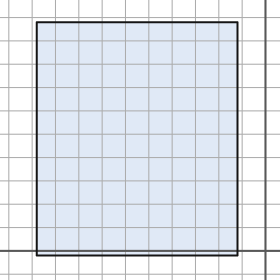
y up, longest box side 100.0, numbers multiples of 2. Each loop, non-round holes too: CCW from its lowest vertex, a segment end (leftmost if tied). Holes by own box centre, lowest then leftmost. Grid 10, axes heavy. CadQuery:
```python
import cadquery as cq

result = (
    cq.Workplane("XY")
    .moveTo(-98.0, -2.0)
    .lineTo(-12.0, -2.0)
    .lineTo(-12.0, 98.0)
    .lineTo(-98.0, 98.0)
    .close()
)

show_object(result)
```